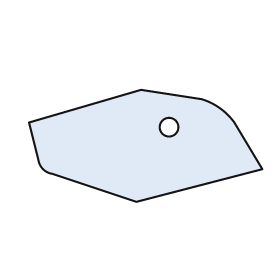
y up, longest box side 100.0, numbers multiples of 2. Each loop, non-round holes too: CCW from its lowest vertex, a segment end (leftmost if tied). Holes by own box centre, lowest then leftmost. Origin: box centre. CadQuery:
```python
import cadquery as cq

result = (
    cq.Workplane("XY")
    .moveTo(-4.0, -24.0)
    .lineTo(50.0, -10.0)
    .lineTo(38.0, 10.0)
    .threePointArc((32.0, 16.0), (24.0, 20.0))
    .lineTo(-2.0, 24.0)
    .lineTo(-50.0, 10.0)
    .lineTo(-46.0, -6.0)
    .threePointArc((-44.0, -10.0), (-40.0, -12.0))
    .close()
    .moveTo(10.0, 8.0)
    .circle(4.0)
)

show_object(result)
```